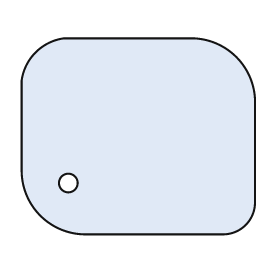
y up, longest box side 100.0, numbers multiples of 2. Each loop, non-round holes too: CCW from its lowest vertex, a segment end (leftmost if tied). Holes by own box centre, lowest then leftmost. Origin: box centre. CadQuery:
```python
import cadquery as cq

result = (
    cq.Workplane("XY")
    .moveTo(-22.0, -42.0)
    .lineTo(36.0, -42.0)
    .threePointArc((46.0, -38.0), (50.0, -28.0))
    .lineTo(50.0, 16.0)
    .threePointArc((42.0, 34.0), (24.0, 42.0))
    .lineTo(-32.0, 42.0)
    .threePointArc((-44.0, 36.0), (-50.0, 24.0))
    .lineTo(-50.0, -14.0)
    .threePointArc((-42.0, -34.0), (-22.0, -42.0))
    .close()
    .moveTo(-30.0, -20.0)
    .circle(4.0)
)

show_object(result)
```